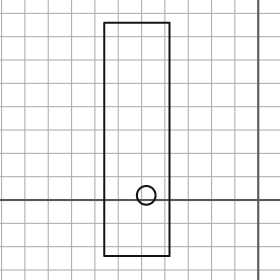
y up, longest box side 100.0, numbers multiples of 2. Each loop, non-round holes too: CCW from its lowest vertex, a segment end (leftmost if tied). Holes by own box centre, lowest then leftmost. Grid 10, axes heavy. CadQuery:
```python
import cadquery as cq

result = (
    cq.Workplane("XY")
    .moveTo(-66.0, -24.0)
    .lineTo(-38.0, -24.0)
    .lineTo(-38.0, 76.0)
    .lineTo(-66.0, 76.0)
    .close()
    .moveTo(-48.0, 2.0)
    .circle(4.0)
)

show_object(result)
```